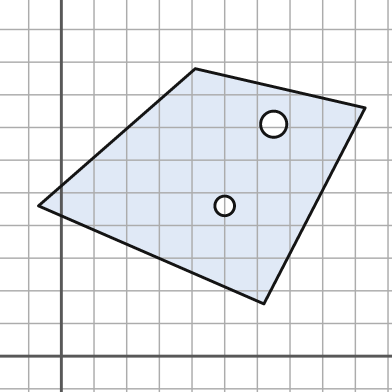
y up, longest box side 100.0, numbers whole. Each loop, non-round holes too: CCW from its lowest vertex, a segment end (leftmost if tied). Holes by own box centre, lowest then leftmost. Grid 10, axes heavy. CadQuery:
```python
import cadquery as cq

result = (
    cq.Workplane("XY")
    .moveTo(62.0, 16.0)
    .lineTo(93.0, 76.0)
    .lineTo(41.0, 88.0)
    .lineTo(-7.0, 46.0)
    .close()
    .moveTo(50.0, 46.0)
    .circle(3.0)
    .moveTo(65.0, 71.0)
    .circle(4.0)
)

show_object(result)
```